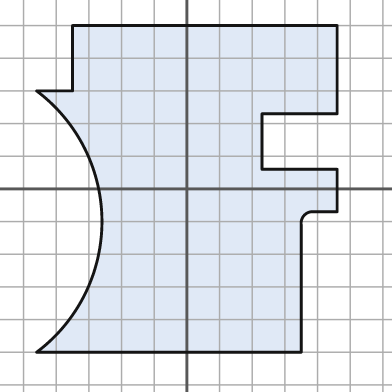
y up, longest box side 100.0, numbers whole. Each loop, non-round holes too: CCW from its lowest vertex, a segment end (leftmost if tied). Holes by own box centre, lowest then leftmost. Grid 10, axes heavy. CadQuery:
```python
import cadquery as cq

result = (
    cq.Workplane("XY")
    .moveTo(-46.0, -50.0)
    .lineTo(35.0, -50.0)
    .lineTo(35.0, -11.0)
    .threePointArc((36.0, -8.0), (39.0, -7.0))
    .lineTo(46.0, -7.0)
    .lineTo(46.0, 6.0)
    .lineTo(23.0, 6.0)
    .lineTo(23.0, 23.0)
    .lineTo(46.0, 23.0)
    .lineTo(46.0, 50.0)
    .lineTo(-35.0, 50.0)
    .lineTo(-35.0, 30.0)
    .lineTo(-46.0, 30.0)
    .threePointArc((-26.0, -10.0), (-46.0, -50.0))
    .close()
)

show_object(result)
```